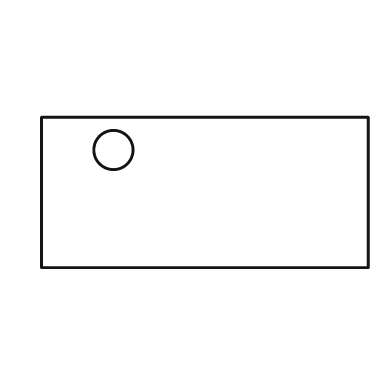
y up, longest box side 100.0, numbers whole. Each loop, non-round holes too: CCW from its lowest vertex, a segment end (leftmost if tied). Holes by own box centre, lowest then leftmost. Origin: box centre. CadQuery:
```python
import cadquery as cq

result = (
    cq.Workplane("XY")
    .moveTo(-50.0, -23.0)
    .lineTo(50.0, -23.0)
    .lineTo(50.0, 23.0)
    .lineTo(-50.0, 23.0)
    .close()
    .moveTo(-28.0, 13.0)
    .circle(6.0)
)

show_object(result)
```